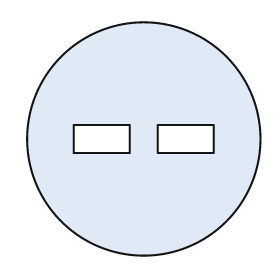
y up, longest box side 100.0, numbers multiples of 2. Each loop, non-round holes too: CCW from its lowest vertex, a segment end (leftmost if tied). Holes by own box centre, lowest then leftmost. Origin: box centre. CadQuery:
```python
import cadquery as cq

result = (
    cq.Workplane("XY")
    .moveTo(0.0, 0.0)
    .circle(50.0)
    .moveTo(-30.0, -6.0)
    .lineTo(-6.0, -6.0)
    .lineTo(-6.0, 6.0)
    .lineTo(-30.0, 6.0)
    .close()
    .moveTo(6.0, -6.0)
    .lineTo(30.0, -6.0)
    .lineTo(30.0, 6.0)
    .lineTo(6.0, 6.0)
    .close()
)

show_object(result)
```